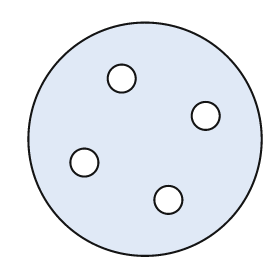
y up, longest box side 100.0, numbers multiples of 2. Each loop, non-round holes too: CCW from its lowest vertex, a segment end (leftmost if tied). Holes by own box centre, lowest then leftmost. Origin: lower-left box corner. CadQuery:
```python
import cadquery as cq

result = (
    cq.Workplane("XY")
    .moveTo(50.0, 50.0)
    .circle(50.0)
    .moveTo(60.0, 24.0)
    .circle(6.0)
    .moveTo(24.0, 40.0)
    .circle(6.0)
    .moveTo(76.0, 60.0)
    .circle(6.0)
    .moveTo(40.0, 76.0)
    .circle(6.0)
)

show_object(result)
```